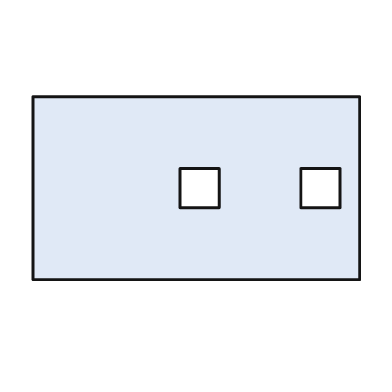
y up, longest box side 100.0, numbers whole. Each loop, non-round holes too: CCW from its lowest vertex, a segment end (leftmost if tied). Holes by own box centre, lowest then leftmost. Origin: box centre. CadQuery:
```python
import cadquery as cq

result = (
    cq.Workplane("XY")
    .moveTo(-50.0, -28.0)
    .lineTo(50.0, -28.0)
    .lineTo(50.0, 28.0)
    .lineTo(-50.0, 28.0)
    .close()
    .moveTo(-5.0, -6.0)
    .lineTo(7.0, -6.0)
    .lineTo(7.0, 6.0)
    .lineTo(-5.0, 6.0)
    .close()
    .moveTo(32.0, -6.0)
    .lineTo(44.0, -6.0)
    .lineTo(44.0, 6.0)
    .lineTo(32.0, 6.0)
    .close()
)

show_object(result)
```